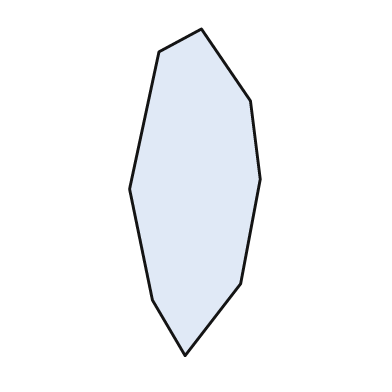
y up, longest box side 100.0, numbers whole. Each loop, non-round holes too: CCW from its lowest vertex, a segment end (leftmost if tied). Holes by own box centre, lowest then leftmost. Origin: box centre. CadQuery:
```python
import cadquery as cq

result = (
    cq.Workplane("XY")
    .moveTo(-3.0, -50.0)
    .lineTo(14.0, -28.0)
    .lineTo(20.0, 4.0)
    .lineTo(17.0, 28.0)
    .lineTo(2.0, 50.0)
    .lineTo(-11.0, 43.0)
    .lineTo(-20.0, 1.0)
    .lineTo(-13.0, -33.0)
    .close()
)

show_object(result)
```